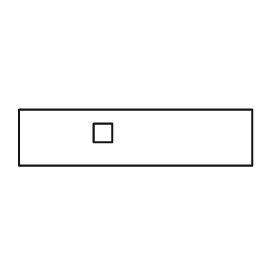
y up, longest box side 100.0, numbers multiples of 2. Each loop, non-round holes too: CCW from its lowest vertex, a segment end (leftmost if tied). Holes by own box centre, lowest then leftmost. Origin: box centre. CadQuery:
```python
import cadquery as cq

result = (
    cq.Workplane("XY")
    .moveTo(-50.0, -12.0)
    .lineTo(50.0, -12.0)
    .lineTo(50.0, 12.0)
    .lineTo(-50.0, 12.0)
    .close()
    .moveTo(-18.0, -2.0)
    .lineTo(-10.0, -2.0)
    .lineTo(-10.0, 6.0)
    .lineTo(-18.0, 6.0)
    .close()
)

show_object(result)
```